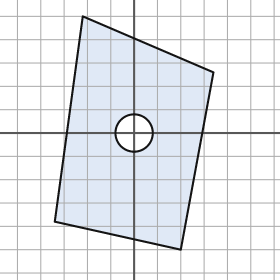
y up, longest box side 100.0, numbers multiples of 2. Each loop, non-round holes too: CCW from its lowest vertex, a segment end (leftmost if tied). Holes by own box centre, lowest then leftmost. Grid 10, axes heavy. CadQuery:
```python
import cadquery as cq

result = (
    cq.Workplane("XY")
    .moveTo(20.0, -50.0)
    .lineTo(34.0, 26.0)
    .lineTo(-22.0, 50.0)
    .lineTo(-34.0, -38.0)
    .close()
    .moveTo(0.0, 0.0)
    .circle(8.0)
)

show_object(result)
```